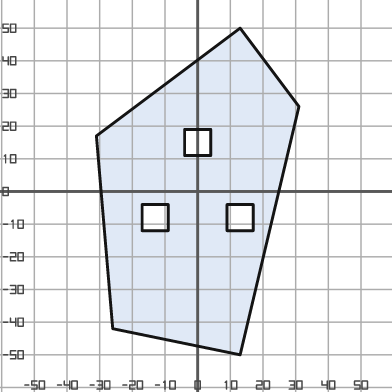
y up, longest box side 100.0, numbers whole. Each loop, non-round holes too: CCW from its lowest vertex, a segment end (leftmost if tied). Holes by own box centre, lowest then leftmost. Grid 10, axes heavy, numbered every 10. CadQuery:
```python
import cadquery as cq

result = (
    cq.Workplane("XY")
    .moveTo(13.0, -50.0)
    .lineTo(31.0, 26.0)
    .lineTo(13.0, 50.0)
    .lineTo(-31.0, 17.0)
    .lineTo(-26.0, -42.0)
    .close()
    .moveTo(-17.0, -12.0)
    .lineTo(-9.0, -12.0)
    .lineTo(-9.0, -4.0)
    .lineTo(-17.0, -4.0)
    .close()
    .moveTo(9.0, -12.0)
    .lineTo(17.0, -12.0)
    .lineTo(17.0, -4.0)
    .lineTo(9.0, -4.0)
    .close()
    .moveTo(-4.0, 11.0)
    .lineTo(4.0, 11.0)
    .lineTo(4.0, 19.0)
    .lineTo(-4.0, 19.0)
    .close()
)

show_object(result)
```